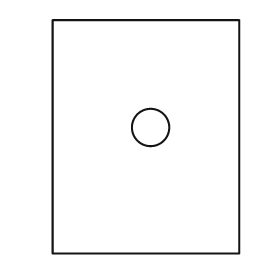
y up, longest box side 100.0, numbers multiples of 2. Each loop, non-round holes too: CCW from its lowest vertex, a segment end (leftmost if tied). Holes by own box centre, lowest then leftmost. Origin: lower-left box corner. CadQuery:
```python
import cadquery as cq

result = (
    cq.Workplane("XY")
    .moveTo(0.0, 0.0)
    .lineTo(80.0, 0.0)
    .lineTo(80.0, 100.0)
    .lineTo(0.0, 100.0)
    .close()
    .moveTo(42.0, 54.0)
    .circle(8.0)
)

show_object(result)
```